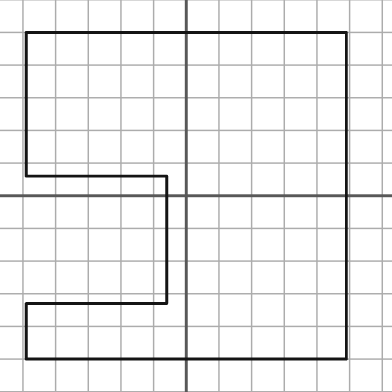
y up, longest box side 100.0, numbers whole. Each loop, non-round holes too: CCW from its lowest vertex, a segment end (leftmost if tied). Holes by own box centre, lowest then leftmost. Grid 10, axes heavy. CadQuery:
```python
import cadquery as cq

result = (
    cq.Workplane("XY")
    .moveTo(-49.0, -50.0)
    .lineTo(49.0, -50.0)
    .lineTo(49.0, 50.0)
    .lineTo(-49.0, 50.0)
    .lineTo(-49.0, 6.0)
    .lineTo(-6.0, 6.0)
    .lineTo(-6.0, -33.0)
    .lineTo(-49.0, -33.0)
    .close()
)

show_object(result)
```